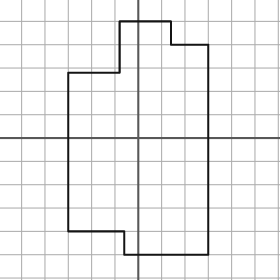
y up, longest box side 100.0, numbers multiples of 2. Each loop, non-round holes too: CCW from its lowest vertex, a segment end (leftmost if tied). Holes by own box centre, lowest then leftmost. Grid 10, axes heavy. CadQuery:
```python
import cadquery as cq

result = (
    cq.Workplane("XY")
    .moveTo(-6.0, -50.0)
    .lineTo(30.0, -50.0)
    .lineTo(30.0, 40.0)
    .lineTo(14.0, 40.0)
    .lineTo(14.0, 50.0)
    .lineTo(-8.0, 50.0)
    .lineTo(-8.0, 28.0)
    .lineTo(-30.0, 28.0)
    .lineTo(-30.0, -40.0)
    .lineTo(-6.0, -40.0)
    .close()
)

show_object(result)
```